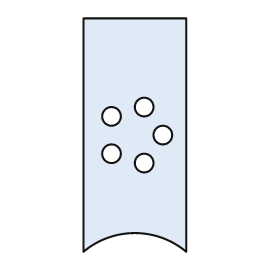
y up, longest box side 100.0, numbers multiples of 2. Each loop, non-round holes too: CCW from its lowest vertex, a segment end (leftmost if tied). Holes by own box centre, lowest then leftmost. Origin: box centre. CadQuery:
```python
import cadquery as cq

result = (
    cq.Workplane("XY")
    .moveTo(-22.0, -50.0)
    .threePointArc((0.0, -42.0), (22.0, -50.0))
    .lineTo(22.0, 50.0)
    .lineTo(-22.0, 50.0)
    .close()
    .moveTo(4.0, -12.0)
    .circle(4.0)
    .moveTo(-10.0, -8.0)
    .circle(4.0)
    .moveTo(12.0, 0.0)
    .circle(4.0)
    .moveTo(-10.0, 8.0)
    .circle(4.0)
    .moveTo(4.0, 12.0)
    .circle(4.0)
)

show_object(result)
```